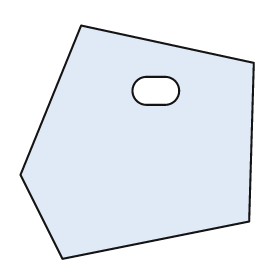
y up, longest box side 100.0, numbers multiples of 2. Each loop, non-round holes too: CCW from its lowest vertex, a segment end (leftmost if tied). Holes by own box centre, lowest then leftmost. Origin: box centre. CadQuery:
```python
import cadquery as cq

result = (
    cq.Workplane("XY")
    .moveTo(-32.0, -50.0)
    .lineTo(48.0, -34.0)
    .lineTo(50.0, 34.0)
    .lineTo(-24.0, 50.0)
    .lineTo(-50.0, -14.0)
    .close()
    .moveTo(4.0, 16.0)
    .lineTo(12.0, 16.0)
    .threePointArc((18.0, 22.0), (12.0, 28.0))
    .lineTo(4.0, 28.0)
    .threePointArc((-2.0, 22.0), (4.0, 16.0))
    .close()
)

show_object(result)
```